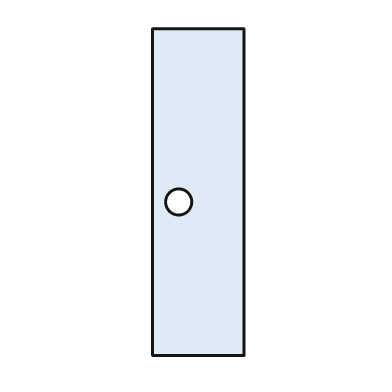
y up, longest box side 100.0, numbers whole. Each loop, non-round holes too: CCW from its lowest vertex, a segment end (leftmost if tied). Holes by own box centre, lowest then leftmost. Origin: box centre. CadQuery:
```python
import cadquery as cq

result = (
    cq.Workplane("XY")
    .moveTo(-14.0, -50.0)
    .lineTo(14.0, -50.0)
    .lineTo(14.0, 50.0)
    .lineTo(-14.0, 50.0)
    .close()
    .moveTo(-6.0, -3.0)
    .circle(4.0)
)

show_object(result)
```